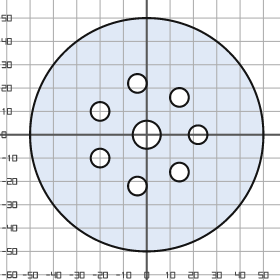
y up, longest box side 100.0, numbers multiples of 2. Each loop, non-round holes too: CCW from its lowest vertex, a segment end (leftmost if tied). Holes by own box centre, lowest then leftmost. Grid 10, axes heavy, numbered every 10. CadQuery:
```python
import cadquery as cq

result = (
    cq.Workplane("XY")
    .moveTo(0.0, 0.0)
    .circle(50.0)
    .moveTo(-4.0, -22.0)
    .circle(4.0)
    .moveTo(14.0, -16.0)
    .circle(4.0)
    .moveTo(-20.0, -10.0)
    .circle(4.0)
    .moveTo(0.0, 0.0)
    .circle(6.0)
    .moveTo(22.0, 0.0)
    .circle(4.0)
    .moveTo(-20.0, 10.0)
    .circle(4.0)
    .moveTo(14.0, 16.0)
    .circle(4.0)
    .moveTo(-4.0, 22.0)
    .circle(4.0)
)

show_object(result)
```